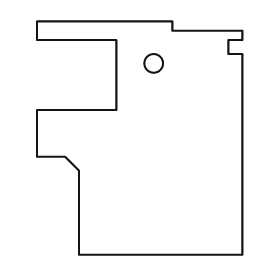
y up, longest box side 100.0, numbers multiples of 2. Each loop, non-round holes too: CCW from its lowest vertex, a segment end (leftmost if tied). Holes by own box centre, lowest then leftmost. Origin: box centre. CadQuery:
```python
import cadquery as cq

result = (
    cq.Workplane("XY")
    .moveTo(-26.0, -50.0)
    .lineTo(44.0, -50.0)
    .lineTo(44.0, 36.0)
    .lineTo(38.0, 36.0)
    .lineTo(38.0, 42.0)
    .lineTo(44.0, 42.0)
    .lineTo(44.0, 46.0)
    .lineTo(14.0, 46.0)
    .lineTo(14.0, 50.0)
    .lineTo(-44.0, 50.0)
    .lineTo(-44.0, 42.0)
    .lineTo(-10.0, 42.0)
    .lineTo(-10.0, 12.0)
    .lineTo(-44.0, 12.0)
    .lineTo(-44.0, -8.0)
    .lineTo(-32.0, -8.0)
    .lineTo(-26.0, -14.0)
    .close()
    .moveTo(6.0, 32.0)
    .circle(4.0)
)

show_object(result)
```